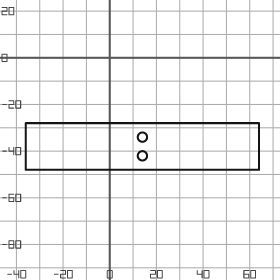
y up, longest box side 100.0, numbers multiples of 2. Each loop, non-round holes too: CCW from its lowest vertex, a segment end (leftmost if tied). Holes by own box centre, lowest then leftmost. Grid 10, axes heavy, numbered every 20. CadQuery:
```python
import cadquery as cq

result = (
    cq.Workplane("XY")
    .moveTo(-36.0, -48.0)
    .lineTo(64.0, -48.0)
    .lineTo(64.0, -28.0)
    .lineTo(-36.0, -28.0)
    .close()
    .moveTo(14.0, -42.0)
    .circle(2.0)
    .moveTo(14.0, -34.0)
    .circle(2.0)
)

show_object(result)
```